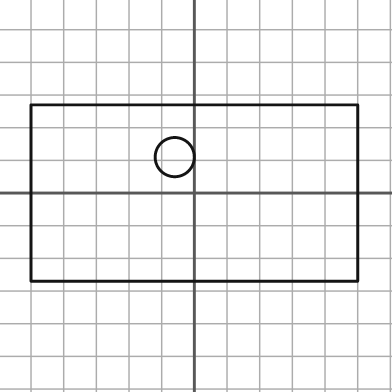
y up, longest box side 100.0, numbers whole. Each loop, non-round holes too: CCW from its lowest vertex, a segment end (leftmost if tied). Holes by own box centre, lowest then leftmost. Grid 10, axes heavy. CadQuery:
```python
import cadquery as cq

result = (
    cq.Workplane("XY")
    .moveTo(-50.0, -27.0)
    .lineTo(50.0, -27.0)
    .lineTo(50.0, 27.0)
    .lineTo(-50.0, 27.0)
    .close()
    .moveTo(-6.0, 11.0)
    .circle(6.0)
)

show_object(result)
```